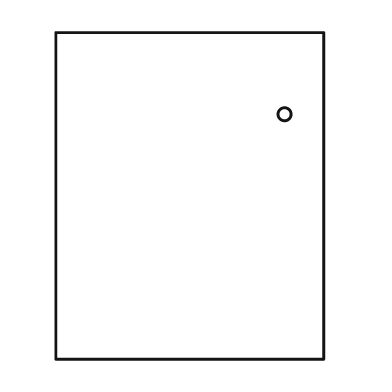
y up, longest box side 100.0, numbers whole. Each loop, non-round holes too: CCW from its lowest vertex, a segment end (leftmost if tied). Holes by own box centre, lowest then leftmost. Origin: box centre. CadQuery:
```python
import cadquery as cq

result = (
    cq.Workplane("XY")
    .moveTo(-41.0, -50.0)
    .lineTo(41.0, -50.0)
    .lineTo(41.0, 50.0)
    .lineTo(-41.0, 50.0)
    .close()
    .moveTo(29.0, 25.0)
    .circle(2.0)
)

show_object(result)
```